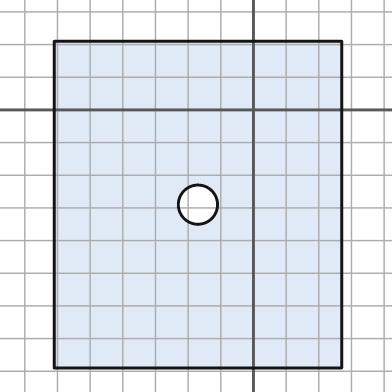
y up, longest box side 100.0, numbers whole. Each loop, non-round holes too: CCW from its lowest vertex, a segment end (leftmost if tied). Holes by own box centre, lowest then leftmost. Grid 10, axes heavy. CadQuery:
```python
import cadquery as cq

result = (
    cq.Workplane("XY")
    .moveTo(-61.0, -79.0)
    .lineTo(27.0, -79.0)
    .lineTo(27.0, 21.0)
    .lineTo(-61.0, 21.0)
    .close()
    .moveTo(-17.0, -29.0)
    .circle(6.0)
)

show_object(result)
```